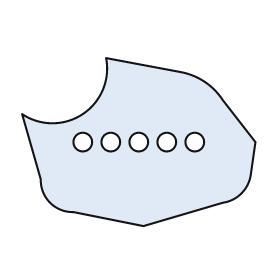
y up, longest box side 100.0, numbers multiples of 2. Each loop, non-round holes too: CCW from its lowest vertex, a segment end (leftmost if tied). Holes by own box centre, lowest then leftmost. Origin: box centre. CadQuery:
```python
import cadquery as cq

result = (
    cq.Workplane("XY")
    .moveTo(2.0, -36.0)
    .lineTo(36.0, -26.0)
    .threePointArc((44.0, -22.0), (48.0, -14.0))
    .lineTo(50.0, 0.0)
    .lineTo(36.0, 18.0)
    .threePointArc((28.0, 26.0), (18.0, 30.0))
    .lineTo(-14.0, 36.0)
    .threePointArc((-24.0, 12.0), (-50.0, 12.0))
    .lineTo(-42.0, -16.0)
    .threePointArc((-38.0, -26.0), (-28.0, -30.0))
    .close()
    .moveTo(-24.0, 0.0)
    .circle(4.0)
    .moveTo(-12.0, 0.0)
    .circle(4.0)
    .moveTo(0.0, 0.0)
    .circle(4.0)
    .moveTo(12.0, 0.0)
    .circle(4.0)
    .moveTo(24.0, 0.0)
    .circle(4.0)
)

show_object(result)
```